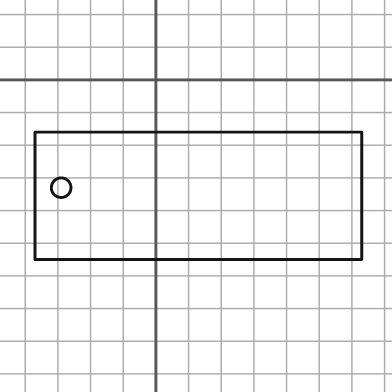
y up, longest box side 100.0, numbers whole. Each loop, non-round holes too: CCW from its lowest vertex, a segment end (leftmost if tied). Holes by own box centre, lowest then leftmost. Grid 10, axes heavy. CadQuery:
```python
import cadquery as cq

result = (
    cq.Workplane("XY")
    .moveTo(-37.0, -55.0)
    .lineTo(63.0, -55.0)
    .lineTo(63.0, -16.0)
    .lineTo(-37.0, -16.0)
    .close()
    .moveTo(-29.0, -33.0)
    .circle(3.0)
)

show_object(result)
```